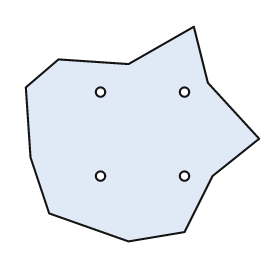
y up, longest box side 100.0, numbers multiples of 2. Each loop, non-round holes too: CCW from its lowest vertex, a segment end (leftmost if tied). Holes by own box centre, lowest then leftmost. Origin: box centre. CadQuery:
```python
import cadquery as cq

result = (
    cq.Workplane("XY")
    .moveTo(-6.0, -46.0)
    .lineTo(18.0, -42.0)
    .lineTo(30.0, -18.0)
    .lineTo(50.0, -2.0)
    .lineTo(28.0, 22.0)
    .lineTo(22.0, 46.0)
    .lineTo(-6.0, 30.0)
    .lineTo(-36.0, 32.0)
    .lineTo(-50.0, 20.0)
    .lineTo(-48.0, -10.0)
    .lineTo(-40.0, -34.0)
    .close()
    .moveTo(-18.0, -18.0)
    .circle(2.0)
    .moveTo(18.0, -18.0)
    .circle(2.0)
    .moveTo(-18.0, 18.0)
    .circle(2.0)
    .moveTo(18.0, 18.0)
    .circle(2.0)
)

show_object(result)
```